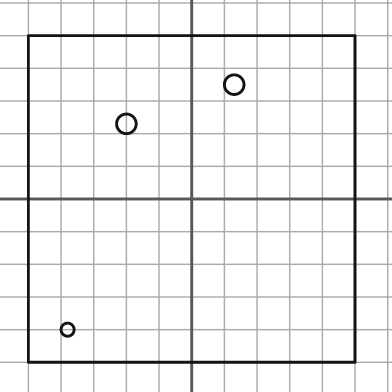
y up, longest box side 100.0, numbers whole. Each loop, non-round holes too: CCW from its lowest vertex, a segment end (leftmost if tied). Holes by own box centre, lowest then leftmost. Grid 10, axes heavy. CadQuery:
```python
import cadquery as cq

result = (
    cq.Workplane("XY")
    .moveTo(-50.0, -50.0)
    .lineTo(50.0, -50.0)
    .lineTo(50.0, 50.0)
    .lineTo(-50.0, 50.0)
    .close()
    .moveTo(-38.0, -40.0)
    .circle(2.0)
    .moveTo(-20.0, 23.0)
    .circle(3.0)
    .moveTo(13.0, 35.0)
    .circle(3.0)
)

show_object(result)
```